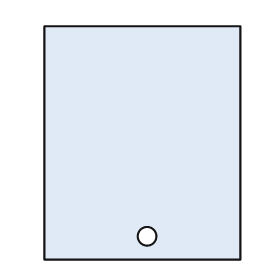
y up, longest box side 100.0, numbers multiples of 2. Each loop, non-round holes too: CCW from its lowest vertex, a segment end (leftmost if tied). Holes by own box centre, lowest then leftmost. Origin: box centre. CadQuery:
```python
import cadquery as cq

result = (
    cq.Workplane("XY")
    .moveTo(-42.0, -50.0)
    .lineTo(42.0, -50.0)
    .lineTo(42.0, 50.0)
    .lineTo(-42.0, 50.0)
    .close()
    .moveTo(2.0, -40.0)
    .circle(4.0)
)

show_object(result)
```